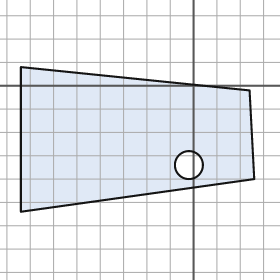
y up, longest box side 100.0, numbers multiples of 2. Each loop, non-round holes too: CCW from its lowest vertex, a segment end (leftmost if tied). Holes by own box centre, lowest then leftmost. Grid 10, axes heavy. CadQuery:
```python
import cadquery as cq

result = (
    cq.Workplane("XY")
    .moveTo(-74.0, -54.0)
    .lineTo(26.0, -40.0)
    .lineTo(24.0, -2.0)
    .lineTo(-74.0, 8.0)
    .close()
    .moveTo(-2.0, -34.0)
    .circle(6.0)
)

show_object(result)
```